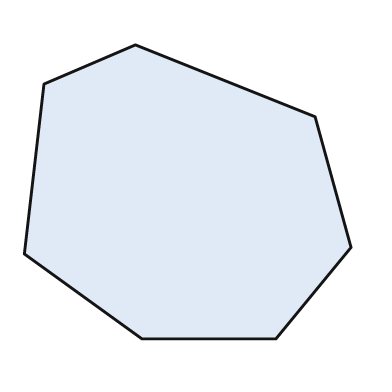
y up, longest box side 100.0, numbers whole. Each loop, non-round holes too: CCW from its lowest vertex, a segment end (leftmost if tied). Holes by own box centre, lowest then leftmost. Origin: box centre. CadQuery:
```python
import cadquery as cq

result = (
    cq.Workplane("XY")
    .moveTo(-14.0, -45.0)
    .lineTo(27.0, -45.0)
    .lineTo(50.0, -17.0)
    .lineTo(39.0, 23.0)
    .lineTo(-16.0, 45.0)
    .lineTo(-44.0, 33.0)
    .lineTo(-50.0, -19.0)
    .close()
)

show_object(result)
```